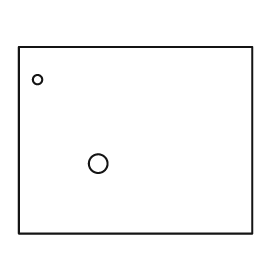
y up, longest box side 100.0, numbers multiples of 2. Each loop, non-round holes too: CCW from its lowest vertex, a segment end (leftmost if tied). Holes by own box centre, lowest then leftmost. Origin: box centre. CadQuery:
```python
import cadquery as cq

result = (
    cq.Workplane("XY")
    .moveTo(-50.0, -40.0)
    .lineTo(50.0, -40.0)
    .lineTo(50.0, 40.0)
    .lineTo(-50.0, 40.0)
    .close()
    .moveTo(-16.0, -10.0)
    .circle(4.0)
    .moveTo(-42.0, 26.0)
    .circle(2.0)
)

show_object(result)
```